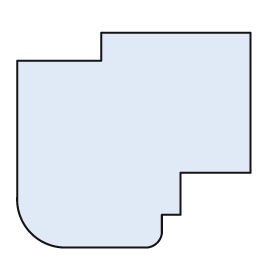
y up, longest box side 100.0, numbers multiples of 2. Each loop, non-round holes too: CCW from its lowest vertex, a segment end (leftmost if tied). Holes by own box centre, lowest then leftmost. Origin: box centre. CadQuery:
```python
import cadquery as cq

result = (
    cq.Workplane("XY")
    .moveTo(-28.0, -46.0)
    .lineTo(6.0, -46.0)
    .threePointArc((10.0, -44.0), (12.0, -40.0))
    .lineTo(12.0, -32.0)
    .lineTo(20.0, -32.0)
    .lineTo(20.0, -14.0)
    .lineTo(50.0, -14.0)
    .lineTo(50.0, 46.0)
    .lineTo(-14.0, 46.0)
    .lineTo(-14.0, 34.0)
    .lineTo(-50.0, 34.0)
    .lineTo(-50.0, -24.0)
    .threePointArc((-44.0, -40.0), (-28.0, -46.0))
    .close()
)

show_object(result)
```